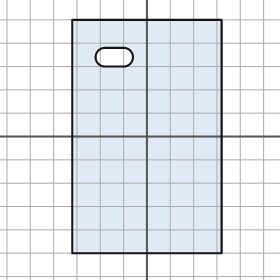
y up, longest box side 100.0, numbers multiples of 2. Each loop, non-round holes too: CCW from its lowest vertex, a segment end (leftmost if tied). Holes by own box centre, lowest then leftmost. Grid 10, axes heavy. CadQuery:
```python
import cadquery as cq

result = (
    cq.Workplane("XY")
    .moveTo(-32.0, -50.0)
    .lineTo(32.0, -50.0)
    .lineTo(32.0, 50.0)
    .lineTo(-32.0, 50.0)
    .close()
    .moveTo(-18.0, 30.0)
    .lineTo(-10.0, 30.0)
    .threePointArc((-6.0, 34.0), (-10.0, 38.0))
    .lineTo(-18.0, 38.0)
    .threePointArc((-22.0, 34.0), (-18.0, 30.0))
    .close()
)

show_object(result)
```